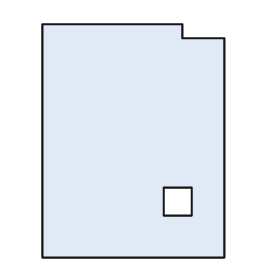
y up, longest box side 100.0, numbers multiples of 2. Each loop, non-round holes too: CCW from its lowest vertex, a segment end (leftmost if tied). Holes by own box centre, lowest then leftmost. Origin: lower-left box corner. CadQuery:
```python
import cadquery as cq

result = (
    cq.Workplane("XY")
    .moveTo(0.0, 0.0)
    .lineTo(78.0, 0.0)
    .lineTo(78.0, 94.0)
    .lineTo(60.0, 94.0)
    .lineTo(60.0, 100.0)
    .lineTo(0.0, 100.0)
    .close()
    .moveTo(52.0, 18.0)
    .lineTo(64.0, 18.0)
    .lineTo(64.0, 30.0)
    .lineTo(52.0, 30.0)
    .close()
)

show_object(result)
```